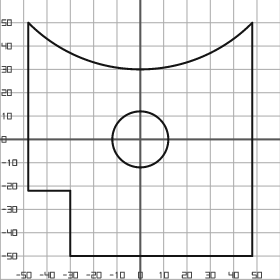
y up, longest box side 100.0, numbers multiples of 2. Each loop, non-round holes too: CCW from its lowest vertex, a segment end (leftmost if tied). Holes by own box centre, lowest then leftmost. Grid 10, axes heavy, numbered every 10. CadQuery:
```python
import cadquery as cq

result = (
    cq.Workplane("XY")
    .moveTo(-30.0, -50.0)
    .lineTo(48.0, -50.0)
    .lineTo(48.0, 50.0)
    .threePointArc((0.0, 30.0), (-48.0, 50.0))
    .lineTo(-48.0, -22.0)
    .lineTo(-30.0, -22.0)
    .close()
    .moveTo(0.0, 0.0)
    .circle(12.0)
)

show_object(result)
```